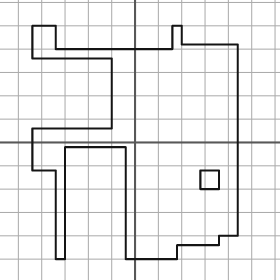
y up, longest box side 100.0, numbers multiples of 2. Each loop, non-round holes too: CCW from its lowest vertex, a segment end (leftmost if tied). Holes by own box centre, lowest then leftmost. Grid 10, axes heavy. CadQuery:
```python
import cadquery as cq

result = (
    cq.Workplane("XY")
    .moveTo(-34.0, -50.0)
    .lineTo(-30.0, -50.0)
    .lineTo(-30.0, -2.0)
    .lineTo(-4.0, -2.0)
    .lineTo(-4.0, -50.0)
    .lineTo(18.0, -50.0)
    .lineTo(18.0, -44.0)
    .lineTo(36.0, -44.0)
    .lineTo(36.0, -40.0)
    .lineTo(44.0, -40.0)
    .lineTo(44.0, 42.0)
    .lineTo(20.0, 42.0)
    .lineTo(20.0, 50.0)
    .lineTo(16.0, 50.0)
    .lineTo(16.0, 40.0)
    .lineTo(-34.0, 40.0)
    .lineTo(-34.0, 50.0)
    .lineTo(-44.0, 50.0)
    .lineTo(-44.0, 36.0)
    .lineTo(-10.0, 36.0)
    .lineTo(-10.0, 6.0)
    .lineTo(-44.0, 6.0)
    .lineTo(-44.0, -12.0)
    .lineTo(-34.0, -12.0)
    .close()
    .moveTo(28.0, -20.0)
    .lineTo(36.0, -20.0)
    .lineTo(36.0, -12.0)
    .lineTo(28.0, -12.0)
    .close()
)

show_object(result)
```